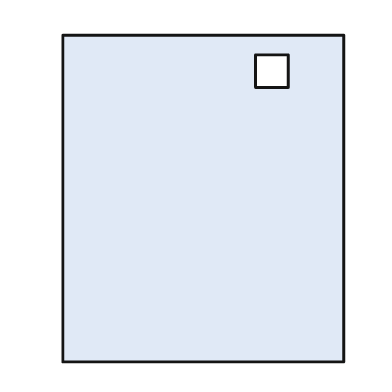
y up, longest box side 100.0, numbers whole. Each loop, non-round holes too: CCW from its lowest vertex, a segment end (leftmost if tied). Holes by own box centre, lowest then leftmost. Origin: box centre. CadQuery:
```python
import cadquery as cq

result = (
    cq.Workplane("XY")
    .moveTo(-43.0, -50.0)
    .lineTo(43.0, -50.0)
    .lineTo(43.0, 50.0)
    .lineTo(-43.0, 50.0)
    .close()
    .moveTo(16.0, 34.0)
    .lineTo(26.0, 34.0)
    .lineTo(26.0, 44.0)
    .lineTo(16.0, 44.0)
    .close()
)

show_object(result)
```